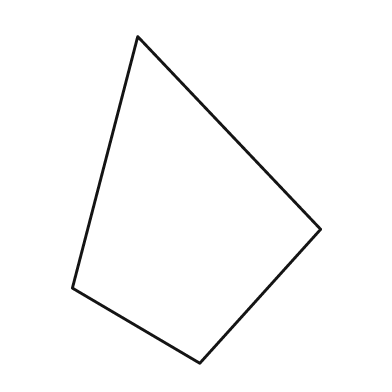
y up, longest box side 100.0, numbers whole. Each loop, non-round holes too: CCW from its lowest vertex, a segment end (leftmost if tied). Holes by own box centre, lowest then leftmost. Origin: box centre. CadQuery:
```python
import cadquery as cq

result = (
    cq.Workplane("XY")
    .moveTo(1.0, -50.0)
    .lineTo(38.0, -9.0)
    .lineTo(-18.0, 50.0)
    .lineTo(-38.0, -27.0)
    .close()
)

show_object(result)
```